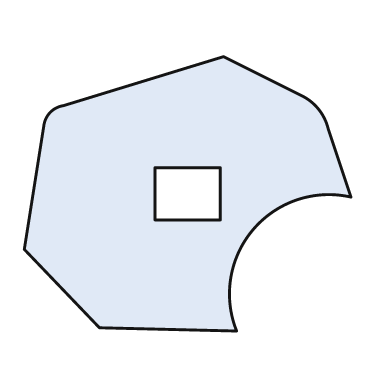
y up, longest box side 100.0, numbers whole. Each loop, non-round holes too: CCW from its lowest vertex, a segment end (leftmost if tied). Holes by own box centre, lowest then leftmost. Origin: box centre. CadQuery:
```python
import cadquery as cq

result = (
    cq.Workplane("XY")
    .moveTo(15.0, -42.0)
    .threePointArc((20.0, -11.0), (50.0, -1.0))
    .lineTo(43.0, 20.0)
    .threePointArc((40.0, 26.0), (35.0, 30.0))
    .lineTo(11.0, 42.0)
    .lineTo(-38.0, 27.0)
    .threePointArc((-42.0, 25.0), (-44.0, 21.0))
    .lineTo(-50.0, -17.0)
    .lineTo(-27.0, -41.0)
    .close()
    .moveTo(-10.0, -8.0)
    .lineTo(10.0, -8.0)
    .lineTo(10.0, 8.0)
    .lineTo(-10.0, 8.0)
    .close()
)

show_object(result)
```